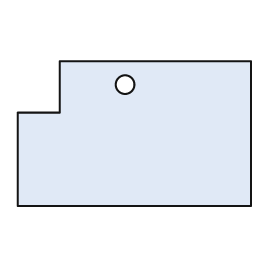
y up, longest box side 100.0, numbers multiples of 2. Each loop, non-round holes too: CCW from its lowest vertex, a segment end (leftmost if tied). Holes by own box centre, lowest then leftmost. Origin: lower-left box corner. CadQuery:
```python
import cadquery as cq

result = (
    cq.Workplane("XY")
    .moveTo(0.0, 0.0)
    .lineTo(100.0, 0.0)
    .lineTo(100.0, 62.0)
    .lineTo(18.0, 62.0)
    .lineTo(18.0, 40.0)
    .lineTo(0.0, 40.0)
    .close()
    .moveTo(46.0, 52.0)
    .circle(4.0)
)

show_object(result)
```